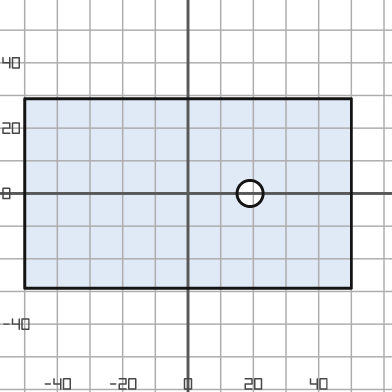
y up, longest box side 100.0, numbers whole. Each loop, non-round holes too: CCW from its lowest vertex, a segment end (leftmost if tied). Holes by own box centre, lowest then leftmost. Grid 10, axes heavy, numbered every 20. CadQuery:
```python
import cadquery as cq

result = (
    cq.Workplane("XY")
    .moveTo(-50.0, -29.0)
    .lineTo(50.0, -29.0)
    .lineTo(50.0, 29.0)
    .lineTo(-50.0, 29.0)
    .close()
    .moveTo(19.0, 0.0)
    .circle(4.0)
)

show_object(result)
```